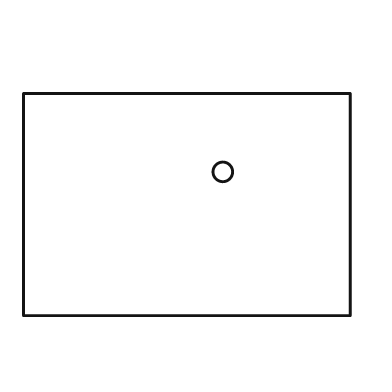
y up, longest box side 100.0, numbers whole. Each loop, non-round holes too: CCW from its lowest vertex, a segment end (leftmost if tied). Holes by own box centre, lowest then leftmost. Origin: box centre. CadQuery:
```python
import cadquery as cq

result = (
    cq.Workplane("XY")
    .moveTo(-50.0, -34.0)
    .lineTo(50.0, -34.0)
    .lineTo(50.0, 34.0)
    .lineTo(-50.0, 34.0)
    .close()
    .moveTo(11.0, 10.0)
    .circle(3.0)
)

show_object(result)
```